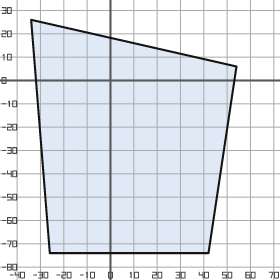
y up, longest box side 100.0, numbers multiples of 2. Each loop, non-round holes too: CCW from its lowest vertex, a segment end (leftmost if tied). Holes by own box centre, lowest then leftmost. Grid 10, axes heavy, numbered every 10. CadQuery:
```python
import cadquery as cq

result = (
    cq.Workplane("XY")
    .moveTo(-26.0, -74.0)
    .lineTo(42.0, -74.0)
    .lineTo(54.0, 6.0)
    .lineTo(-34.0, 26.0)
    .close()
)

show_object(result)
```